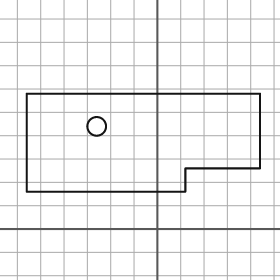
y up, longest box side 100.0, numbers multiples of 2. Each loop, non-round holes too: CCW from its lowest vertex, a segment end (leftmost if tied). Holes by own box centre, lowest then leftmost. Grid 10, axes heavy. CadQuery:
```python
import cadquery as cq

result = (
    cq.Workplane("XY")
    .moveTo(-56.0, 16.0)
    .lineTo(12.0, 16.0)
    .lineTo(12.0, 26.0)
    .lineTo(44.0, 26.0)
    .lineTo(44.0, 58.0)
    .lineTo(-56.0, 58.0)
    .close()
    .moveTo(-26.0, 44.0)
    .circle(4.0)
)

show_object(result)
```